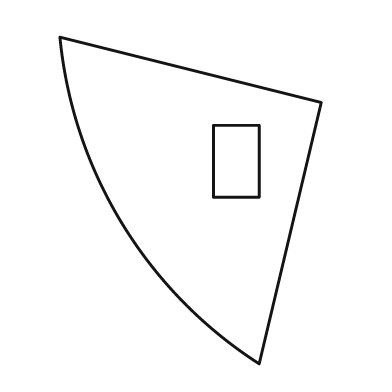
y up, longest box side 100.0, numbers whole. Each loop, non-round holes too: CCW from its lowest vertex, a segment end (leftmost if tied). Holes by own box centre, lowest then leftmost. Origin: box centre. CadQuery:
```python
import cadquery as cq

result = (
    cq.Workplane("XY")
    .moveTo(21.0, -50.0)
    .lineTo(40.0, 30.0)
    .lineTo(-40.0, 50.0)
    .threePointArc((-21.0, -7.0), (21.0, -50.0))
    .close()
    .moveTo(7.0, 1.0)
    .lineTo(21.0, 1.0)
    .lineTo(21.0, 23.0)
    .lineTo(7.0, 23.0)
    .close()
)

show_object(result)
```